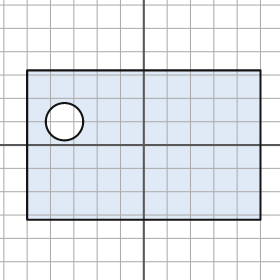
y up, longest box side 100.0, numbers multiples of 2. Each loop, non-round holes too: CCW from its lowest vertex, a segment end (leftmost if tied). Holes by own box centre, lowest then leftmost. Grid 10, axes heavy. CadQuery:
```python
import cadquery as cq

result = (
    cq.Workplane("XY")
    .moveTo(-50.0, -32.0)
    .lineTo(50.0, -32.0)
    .lineTo(50.0, 32.0)
    .lineTo(-50.0, 32.0)
    .close()
    .moveTo(-34.0, 10.0)
    .circle(8.0)
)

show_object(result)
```